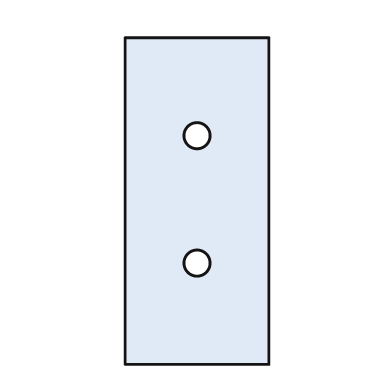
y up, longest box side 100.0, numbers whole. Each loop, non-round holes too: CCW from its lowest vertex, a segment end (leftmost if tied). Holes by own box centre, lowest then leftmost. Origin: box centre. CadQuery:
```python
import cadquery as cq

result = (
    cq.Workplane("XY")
    .moveTo(-22.0, -50.0)
    .lineTo(22.0, -50.0)
    .lineTo(22.0, 50.0)
    .lineTo(-22.0, 50.0)
    .close()
    .moveTo(0.0, -19.0)
    .circle(4.0)
    .moveTo(0.0, 20.0)
    .circle(4.0)
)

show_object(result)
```